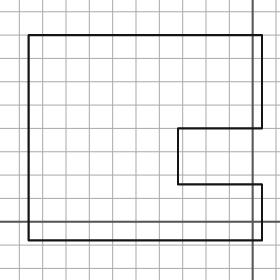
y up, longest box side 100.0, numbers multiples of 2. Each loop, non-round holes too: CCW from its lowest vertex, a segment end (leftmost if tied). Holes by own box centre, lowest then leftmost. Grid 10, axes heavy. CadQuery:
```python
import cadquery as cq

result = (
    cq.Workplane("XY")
    .moveTo(-96.0, -8.0)
    .lineTo(4.0, -8.0)
    .lineTo(4.0, 16.0)
    .lineTo(-32.0, 16.0)
    .lineTo(-32.0, 40.0)
    .lineTo(4.0, 40.0)
    .lineTo(4.0, 80.0)
    .lineTo(-96.0, 80.0)
    .close()
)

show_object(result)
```